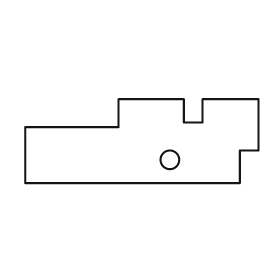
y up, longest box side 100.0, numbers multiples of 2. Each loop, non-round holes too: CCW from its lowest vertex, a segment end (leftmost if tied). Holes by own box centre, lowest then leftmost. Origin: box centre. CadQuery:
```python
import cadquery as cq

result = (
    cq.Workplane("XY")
    .moveTo(-50.0, -18.0)
    .lineTo(42.0, -18.0)
    .lineTo(42.0, -4.0)
    .lineTo(50.0, -4.0)
    .lineTo(50.0, 18.0)
    .lineTo(26.0, 18.0)
    .lineTo(26.0, 8.0)
    .lineTo(18.0, 8.0)
    .lineTo(18.0, 18.0)
    .lineTo(-10.0, 18.0)
    .lineTo(-10.0, 6.0)
    .lineTo(-50.0, 6.0)
    .close()
    .moveTo(12.0, -8.0)
    .circle(4.0)
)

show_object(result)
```